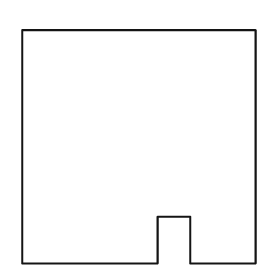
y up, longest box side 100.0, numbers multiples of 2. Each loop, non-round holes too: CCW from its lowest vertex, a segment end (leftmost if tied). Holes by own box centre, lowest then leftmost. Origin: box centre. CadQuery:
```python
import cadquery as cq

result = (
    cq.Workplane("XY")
    .moveTo(-50.0, -50.0)
    .lineTo(8.0, -50.0)
    .lineTo(8.0, -30.0)
    .lineTo(22.0, -30.0)
    .lineTo(22.0, -50.0)
    .lineTo(50.0, -50.0)
    .lineTo(50.0, 50.0)
    .lineTo(-50.0, 50.0)
    .close()
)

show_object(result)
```